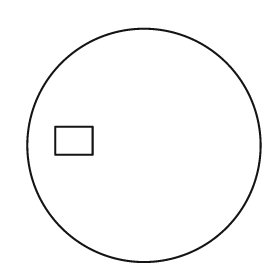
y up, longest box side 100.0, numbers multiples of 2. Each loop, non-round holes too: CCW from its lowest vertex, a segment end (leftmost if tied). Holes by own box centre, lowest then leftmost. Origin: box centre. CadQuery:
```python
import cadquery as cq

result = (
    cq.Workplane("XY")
    .moveTo(0.0, 0.0)
    .circle(50.0)
    .moveTo(-38.0, -4.0)
    .lineTo(-22.0, -4.0)
    .lineTo(-22.0, 8.0)
    .lineTo(-38.0, 8.0)
    .close()
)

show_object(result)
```